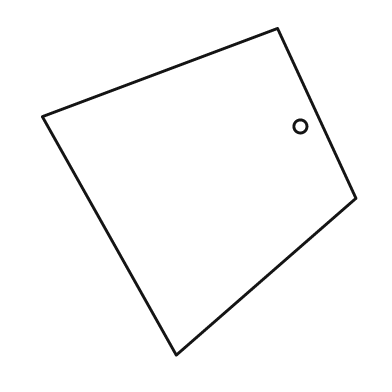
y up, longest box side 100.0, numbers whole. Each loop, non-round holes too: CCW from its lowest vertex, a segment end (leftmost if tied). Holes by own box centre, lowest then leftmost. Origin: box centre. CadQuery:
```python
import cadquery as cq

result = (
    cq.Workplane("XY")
    .moveTo(-7.0, -50.0)
    .lineTo(48.0, -2.0)
    .lineTo(24.0, 50.0)
    .lineTo(-48.0, 23.0)
    .close()
    .moveTo(31.0, 20.0)
    .circle(2.0)
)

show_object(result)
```